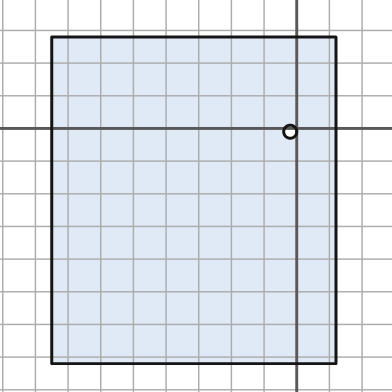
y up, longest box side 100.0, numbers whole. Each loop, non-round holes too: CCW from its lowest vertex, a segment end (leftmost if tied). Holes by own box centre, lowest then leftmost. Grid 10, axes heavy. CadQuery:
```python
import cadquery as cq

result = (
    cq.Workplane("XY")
    .moveTo(-75.0, -72.0)
    .lineTo(12.0, -72.0)
    .lineTo(12.0, 28.0)
    .lineTo(-75.0, 28.0)
    .close()
    .moveTo(-2.0, -1.0)
    .circle(2.0)
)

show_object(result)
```